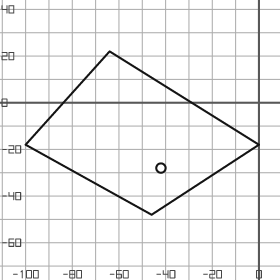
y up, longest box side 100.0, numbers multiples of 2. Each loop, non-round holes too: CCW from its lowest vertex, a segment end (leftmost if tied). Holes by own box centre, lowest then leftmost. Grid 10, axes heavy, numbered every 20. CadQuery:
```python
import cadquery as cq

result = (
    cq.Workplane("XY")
    .moveTo(-46.0, -48.0)
    .lineTo(0.0, -18.0)
    .lineTo(-64.0, 22.0)
    .lineTo(-100.0, -18.0)
    .close()
    .moveTo(-42.0, -28.0)
    .circle(2.0)
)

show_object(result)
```